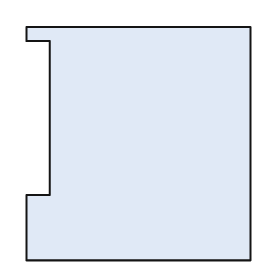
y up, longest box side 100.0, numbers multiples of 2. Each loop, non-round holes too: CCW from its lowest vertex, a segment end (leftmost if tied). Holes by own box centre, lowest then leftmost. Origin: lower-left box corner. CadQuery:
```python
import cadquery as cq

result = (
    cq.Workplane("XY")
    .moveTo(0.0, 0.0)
    .lineTo(96.0, 0.0)
    .lineTo(96.0, 100.0)
    .lineTo(0.0, 100.0)
    .lineTo(0.0, 94.0)
    .lineTo(10.0, 94.0)
    .lineTo(10.0, 28.0)
    .lineTo(0.0, 28.0)
    .close()
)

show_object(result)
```